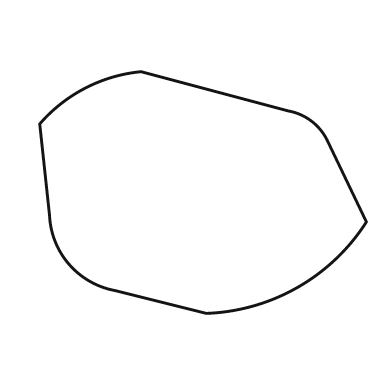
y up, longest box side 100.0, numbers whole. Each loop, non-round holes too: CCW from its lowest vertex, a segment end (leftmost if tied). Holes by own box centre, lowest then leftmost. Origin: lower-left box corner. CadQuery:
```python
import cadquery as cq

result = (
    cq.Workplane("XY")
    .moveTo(51.0, 0.0)
    .threePointArc((79.0, 8.0), (100.0, 28.0))
    .lineTo(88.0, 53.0)
    .threePointArc((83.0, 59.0), (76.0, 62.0))
    .lineTo(31.0, 74.0)
    .threePointArc((14.0, 69.0), (0.0, 58.0))
    .lineTo(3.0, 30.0)
    .threePointArc((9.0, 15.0), (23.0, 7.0))
    .close()
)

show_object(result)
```